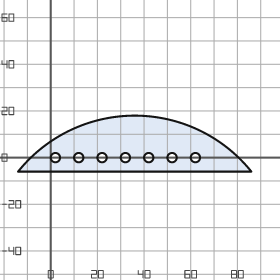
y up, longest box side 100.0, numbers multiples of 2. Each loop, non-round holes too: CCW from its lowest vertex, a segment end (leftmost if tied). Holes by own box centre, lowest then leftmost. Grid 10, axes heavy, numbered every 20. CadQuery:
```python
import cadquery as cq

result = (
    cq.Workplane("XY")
    .moveTo(-14.0, -6.0)
    .lineTo(86.0, -6.0)
    .threePointArc((36.0, 18.0), (-14.0, -6.0))
    .close()
    .moveTo(2.0, 0.0)
    .circle(2.0)
    .moveTo(12.0, 0.0)
    .circle(2.0)
    .moveTo(22.0, 0.0)
    .circle(2.0)
    .moveTo(32.0, 0.0)
    .circle(2.0)
    .moveTo(42.0, 0.0)
    .circle(2.0)
    .moveTo(52.0, 0.0)
    .circle(2.0)
    .moveTo(62.0, 0.0)
    .circle(2.0)
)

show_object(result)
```